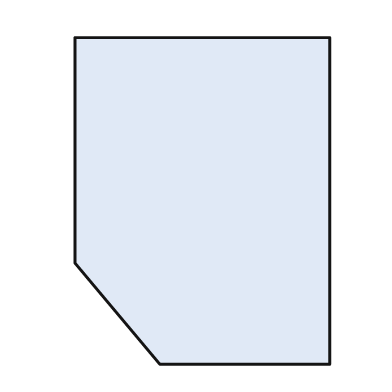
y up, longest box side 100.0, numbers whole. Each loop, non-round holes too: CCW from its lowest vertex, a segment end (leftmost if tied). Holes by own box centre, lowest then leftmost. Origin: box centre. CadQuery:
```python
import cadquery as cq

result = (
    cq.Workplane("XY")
    .moveTo(-13.0, -50.0)
    .lineTo(39.0, -50.0)
    .lineTo(39.0, 50.0)
    .lineTo(-39.0, 50.0)
    .lineTo(-39.0, -19.0)
    .close()
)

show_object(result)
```